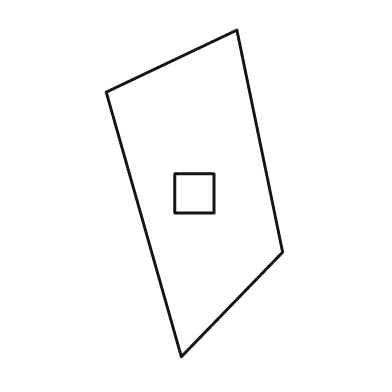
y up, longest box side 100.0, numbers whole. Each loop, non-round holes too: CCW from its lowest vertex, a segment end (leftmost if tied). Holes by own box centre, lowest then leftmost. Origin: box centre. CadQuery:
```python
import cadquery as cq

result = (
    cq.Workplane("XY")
    .moveTo(-4.0, -50.0)
    .lineTo(27.0, -18.0)
    .lineTo(13.0, 50.0)
    .lineTo(-27.0, 31.0)
    .close()
    .moveTo(-6.0, -6.0)
    .lineTo(6.0, -6.0)
    .lineTo(6.0, 6.0)
    .lineTo(-6.0, 6.0)
    .close()
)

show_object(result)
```